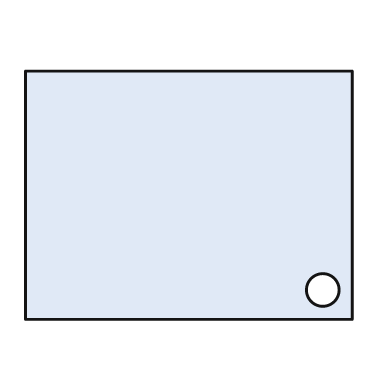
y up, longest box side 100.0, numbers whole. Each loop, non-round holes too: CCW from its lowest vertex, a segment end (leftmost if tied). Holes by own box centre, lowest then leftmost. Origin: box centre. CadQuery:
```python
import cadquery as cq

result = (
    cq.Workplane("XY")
    .moveTo(-50.0, -38.0)
    .lineTo(50.0, -38.0)
    .lineTo(50.0, 38.0)
    .lineTo(-50.0, 38.0)
    .close()
    .moveTo(41.0, -29.0)
    .circle(5.0)
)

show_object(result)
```